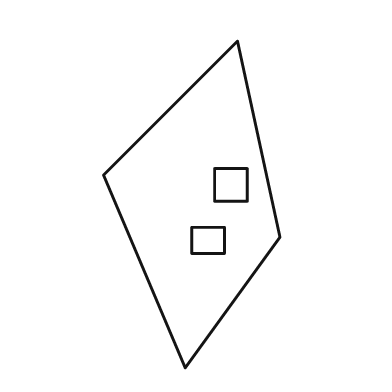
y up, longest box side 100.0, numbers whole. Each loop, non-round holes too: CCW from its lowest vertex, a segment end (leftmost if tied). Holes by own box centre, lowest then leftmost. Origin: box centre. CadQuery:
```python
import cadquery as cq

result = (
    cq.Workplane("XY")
    .moveTo(-2.0, -50.0)
    .lineTo(27.0, -10.0)
    .lineTo(14.0, 50.0)
    .lineTo(-27.0, 9.0)
    .close()
    .moveTo(0.0, -15.0)
    .lineTo(10.0, -15.0)
    .lineTo(10.0, -7.0)
    .lineTo(0.0, -7.0)
    .close()
    .moveTo(7.0, 1.0)
    .lineTo(17.0, 1.0)
    .lineTo(17.0, 11.0)
    .lineTo(7.0, 11.0)
    .close()
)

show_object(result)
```